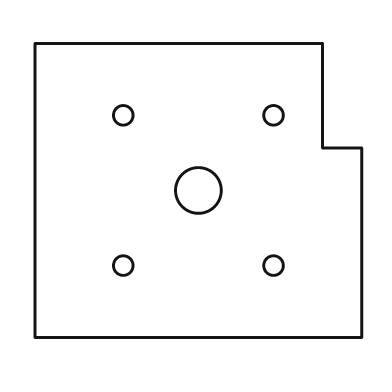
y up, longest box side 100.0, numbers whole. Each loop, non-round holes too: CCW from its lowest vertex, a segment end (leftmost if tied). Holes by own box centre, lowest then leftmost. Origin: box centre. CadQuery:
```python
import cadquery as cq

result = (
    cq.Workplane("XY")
    .moveTo(-50.0, -45.0)
    .lineTo(50.0, -45.0)
    .lineTo(50.0, 13.0)
    .lineTo(38.0, 13.0)
    .lineTo(38.0, 45.0)
    .lineTo(-50.0, 45.0)
    .close()
    .moveTo(-23.0, -23.0)
    .circle(3.0)
    .moveTo(23.0, -23.0)
    .circle(3.0)
    .moveTo(0.0, 0.0)
    .circle(7.0)
    .moveTo(-23.0, 23.0)
    .circle(3.0)
    .moveTo(23.0, 23.0)
    .circle(3.0)
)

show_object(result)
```